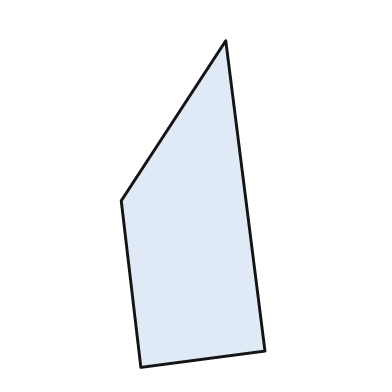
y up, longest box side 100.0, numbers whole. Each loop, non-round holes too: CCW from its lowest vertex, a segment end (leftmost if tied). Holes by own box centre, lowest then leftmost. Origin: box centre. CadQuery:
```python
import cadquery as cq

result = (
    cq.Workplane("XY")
    .moveTo(-16.0, -50.0)
    .lineTo(22.0, -45.0)
    .lineTo(10.0, 50.0)
    .lineTo(-22.0, 1.0)
    .close()
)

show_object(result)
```